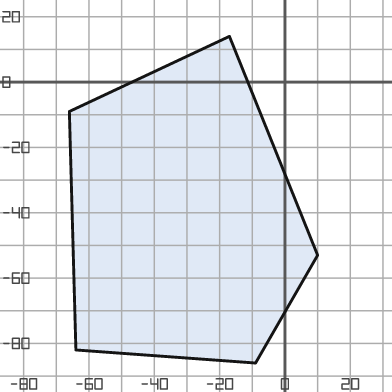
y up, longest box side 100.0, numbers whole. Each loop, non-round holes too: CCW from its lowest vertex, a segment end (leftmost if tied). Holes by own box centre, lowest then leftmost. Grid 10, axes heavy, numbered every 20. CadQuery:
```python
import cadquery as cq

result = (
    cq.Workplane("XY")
    .moveTo(-9.0, -86.0)
    .lineTo(10.0, -53.0)
    .lineTo(-17.0, 14.0)
    .lineTo(-66.0, -9.0)
    .lineTo(-64.0, -82.0)
    .close()
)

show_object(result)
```